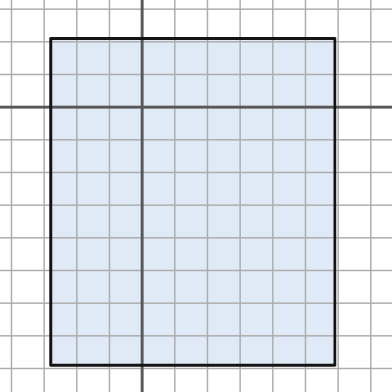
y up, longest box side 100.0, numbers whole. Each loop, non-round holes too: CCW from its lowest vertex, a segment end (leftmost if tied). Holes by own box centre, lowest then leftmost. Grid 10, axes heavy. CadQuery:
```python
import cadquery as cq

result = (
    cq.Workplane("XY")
    .moveTo(-28.0, -79.0)
    .lineTo(59.0, -79.0)
    .lineTo(59.0, 21.0)
    .lineTo(-28.0, 21.0)
    .close()
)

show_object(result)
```